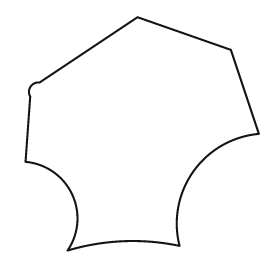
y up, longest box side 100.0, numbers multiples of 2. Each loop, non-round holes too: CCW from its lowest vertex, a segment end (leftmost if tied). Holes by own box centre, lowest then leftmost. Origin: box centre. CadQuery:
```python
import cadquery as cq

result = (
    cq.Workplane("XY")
    .moveTo(-32.0, -50.0)
    .threePointArc((-8.0, -46.0), (16.0, -48.0))
    .threePointArc((22.0, -16.0), (50.0, 0.0))
    .lineTo(38.0, 36.0)
    .lineTo(-2.0, 50.0)
    .lineTo(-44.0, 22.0)
    .threePointArc((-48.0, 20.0), (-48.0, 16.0))
    .lineTo(-50.0, -12.0)
    .threePointArc((-30.0, -26.0), (-32.0, -50.0))
    .close()
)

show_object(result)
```